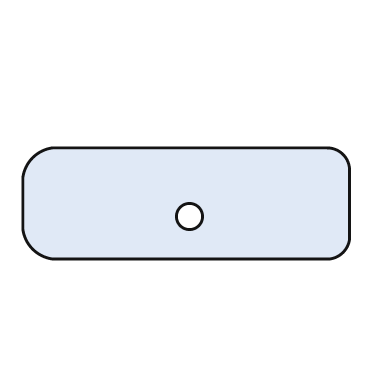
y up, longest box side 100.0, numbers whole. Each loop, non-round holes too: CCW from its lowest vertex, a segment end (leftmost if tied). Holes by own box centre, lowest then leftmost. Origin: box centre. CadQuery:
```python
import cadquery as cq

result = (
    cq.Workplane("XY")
    .moveTo(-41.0, -17.0)
    .lineTo(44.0, -17.0)
    .threePointArc((48.0, -15.0), (50.0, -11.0))
    .lineTo(50.0, 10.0)
    .threePointArc((48.0, 15.0), (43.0, 17.0))
    .lineTo(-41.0, 17.0)
    .threePointArc((-47.0, 14.0), (-50.0, 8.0))
    .lineTo(-50.0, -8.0)
    .threePointArc((-47.0, -14.0), (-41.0, -17.0))
    .close()
    .moveTo(1.0, -4.0)
    .circle(4.0)
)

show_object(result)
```